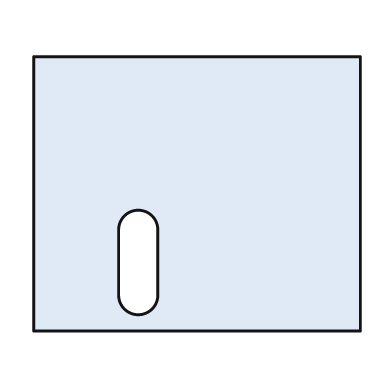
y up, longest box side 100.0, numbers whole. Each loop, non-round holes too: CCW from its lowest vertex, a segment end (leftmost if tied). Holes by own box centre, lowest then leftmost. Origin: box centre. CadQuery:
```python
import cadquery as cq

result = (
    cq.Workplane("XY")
    .moveTo(-50.0, -42.0)
    .lineTo(50.0, -42.0)
    .lineTo(50.0, 42.0)
    .lineTo(-50.0, 42.0)
    .close()
    .moveTo(-24.0, -31.0)
    .threePointArc((-18.0, -37.0), (-12.0, -31.0))
    .lineTo(-12.0, -11.0)
    .threePointArc((-18.0, -5.0), (-24.0, -11.0))
    .close()
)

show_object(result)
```